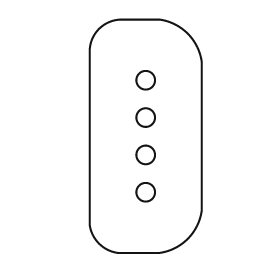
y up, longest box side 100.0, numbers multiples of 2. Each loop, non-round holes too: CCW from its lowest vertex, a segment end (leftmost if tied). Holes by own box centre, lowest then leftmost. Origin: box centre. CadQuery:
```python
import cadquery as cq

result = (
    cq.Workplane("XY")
    .moveTo(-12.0, -50.0)
    .lineTo(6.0, -50.0)
    .threePointArc((18.0, -44.0), (24.0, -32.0))
    .lineTo(24.0, 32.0)
    .threePointArc((18.0, 44.0), (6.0, 50.0))
    .lineTo(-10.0, 50.0)
    .threePointArc((-20.0, 46.0), (-24.0, 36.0))
    .lineTo(-24.0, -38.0)
    .threePointArc((-20.0, -46.0), (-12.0, -50.0))
    .close()
    .moveTo(0.0, -24.0)
    .circle(4.0)
    .moveTo(0.0, -8.0)
    .circle(4.0)
    .moveTo(0.0, 8.0)
    .circle(4.0)
    .moveTo(0.0, 24.0)
    .circle(4.0)
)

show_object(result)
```